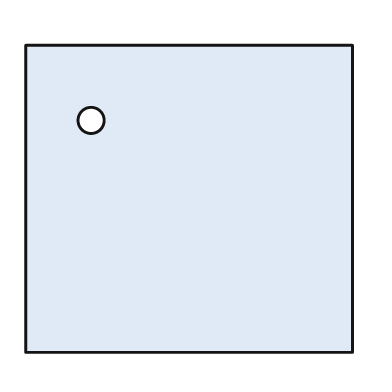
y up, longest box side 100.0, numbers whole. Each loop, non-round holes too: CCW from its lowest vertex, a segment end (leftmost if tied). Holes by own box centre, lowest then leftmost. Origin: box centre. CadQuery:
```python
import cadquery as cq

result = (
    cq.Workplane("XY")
    .moveTo(-50.0, -47.0)
    .lineTo(50.0, -47.0)
    .lineTo(50.0, 47.0)
    .lineTo(-50.0, 47.0)
    .close()
    .moveTo(-30.0, 24.0)
    .circle(4.0)
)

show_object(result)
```